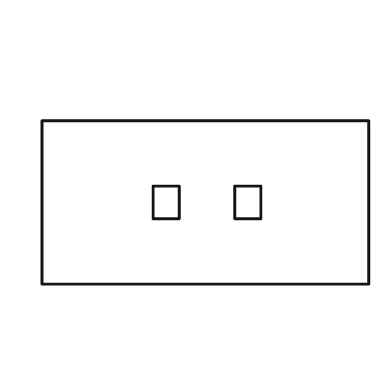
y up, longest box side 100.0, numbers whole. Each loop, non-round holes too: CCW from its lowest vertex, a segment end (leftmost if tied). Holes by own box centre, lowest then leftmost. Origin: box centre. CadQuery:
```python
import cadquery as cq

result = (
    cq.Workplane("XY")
    .moveTo(-50.0, -25.0)
    .lineTo(50.0, -25.0)
    .lineTo(50.0, 25.0)
    .lineTo(-50.0, 25.0)
    .close()
    .moveTo(-16.0, -5.0)
    .lineTo(-8.0, -5.0)
    .lineTo(-8.0, 5.0)
    .lineTo(-16.0, 5.0)
    .close()
    .moveTo(9.0, -5.0)
    .lineTo(17.0, -5.0)
    .lineTo(17.0, 5.0)
    .lineTo(9.0, 5.0)
    .close()
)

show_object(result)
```